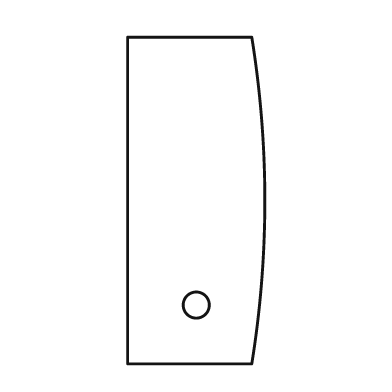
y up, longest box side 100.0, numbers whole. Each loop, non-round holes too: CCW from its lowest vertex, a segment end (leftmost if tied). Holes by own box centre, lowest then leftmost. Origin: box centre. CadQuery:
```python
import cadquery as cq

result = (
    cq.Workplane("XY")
    .moveTo(-21.0, -50.0)
    .lineTo(17.0, -50.0)
    .threePointArc((21.0, 0.0), (17.0, 50.0))
    .lineTo(-21.0, 50.0)
    .close()
    .moveTo(0.0, -32.0)
    .circle(4.0)
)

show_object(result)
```